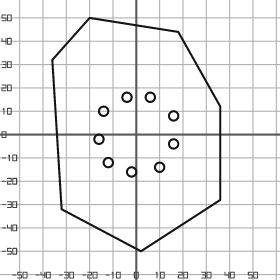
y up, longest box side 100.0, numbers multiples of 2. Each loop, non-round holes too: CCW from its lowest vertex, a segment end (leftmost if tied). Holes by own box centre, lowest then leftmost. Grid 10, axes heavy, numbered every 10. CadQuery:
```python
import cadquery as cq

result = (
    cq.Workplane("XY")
    .moveTo(2.0, -50.0)
    .lineTo(36.0, -28.0)
    .lineTo(36.0, 12.0)
    .lineTo(18.0, 44.0)
    .lineTo(-20.0, 50.0)
    .lineTo(-36.0, 32.0)
    .lineTo(-32.0, -32.0)
    .close()
    .moveTo(-2.0, -16.0)
    .circle(2.0)
    .moveTo(10.0, -14.0)
    .circle(2.0)
    .moveTo(-12.0, -12.0)
    .circle(2.0)
    .moveTo(16.0, -4.0)
    .circle(2.0)
    .moveTo(-16.0, -2.0)
    .circle(2.0)
    .moveTo(16.0, 8.0)
    .circle(2.0)
    .moveTo(-14.0, 10.0)
    .circle(2.0)
    .moveTo(-4.0, 16.0)
    .circle(2.0)
    .moveTo(6.0, 16.0)
    .circle(2.0)
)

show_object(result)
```